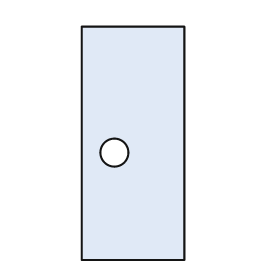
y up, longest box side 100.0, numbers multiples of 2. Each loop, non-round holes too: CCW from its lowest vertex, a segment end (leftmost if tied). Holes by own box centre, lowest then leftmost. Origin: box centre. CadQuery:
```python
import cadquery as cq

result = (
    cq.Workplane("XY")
    .moveTo(-22.0, -50.0)
    .lineTo(22.0, -50.0)
    .lineTo(22.0, 50.0)
    .lineTo(-22.0, 50.0)
    .close()
    .moveTo(-8.0, -4.0)
    .circle(6.0)
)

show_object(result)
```